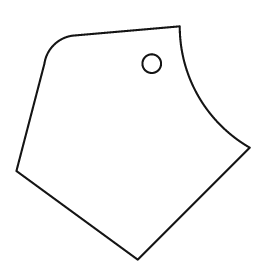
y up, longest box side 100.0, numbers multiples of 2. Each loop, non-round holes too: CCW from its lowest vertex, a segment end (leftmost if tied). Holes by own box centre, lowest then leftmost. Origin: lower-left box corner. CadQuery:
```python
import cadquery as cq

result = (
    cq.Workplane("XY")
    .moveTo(52.0, 0.0)
    .lineTo(100.0, 48.0)
    .threePointArc((78.0, 70.0), (70.0, 100.0))
    .lineTo(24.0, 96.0)
    .threePointArc((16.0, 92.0), (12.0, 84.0))
    .lineTo(0.0, 38.0)
    .close()
    .moveTo(58.0, 84.0)
    .circle(4.0)
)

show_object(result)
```